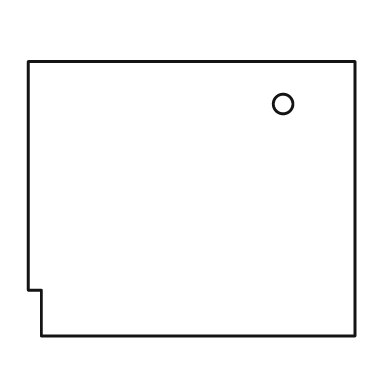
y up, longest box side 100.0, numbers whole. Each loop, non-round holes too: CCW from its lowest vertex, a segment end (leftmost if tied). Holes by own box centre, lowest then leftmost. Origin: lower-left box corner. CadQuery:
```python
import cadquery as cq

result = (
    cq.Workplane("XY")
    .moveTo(4.0, 0.0)
    .lineTo(100.0, 0.0)
    .lineTo(100.0, 84.0)
    .lineTo(0.0, 84.0)
    .lineTo(0.0, 14.0)
    .lineTo(4.0, 14.0)
    .close()
    .moveTo(78.0, 71.0)
    .circle(3.0)
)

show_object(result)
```